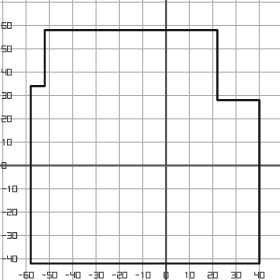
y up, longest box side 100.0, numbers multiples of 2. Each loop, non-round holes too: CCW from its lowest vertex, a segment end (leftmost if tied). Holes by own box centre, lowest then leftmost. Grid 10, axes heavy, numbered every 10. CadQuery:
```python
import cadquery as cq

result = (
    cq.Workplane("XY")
    .moveTo(-58.0, -42.0)
    .lineTo(40.0, -42.0)
    .lineTo(40.0, 28.0)
    .lineTo(22.0, 28.0)
    .lineTo(22.0, 58.0)
    .lineTo(-52.0, 58.0)
    .lineTo(-52.0, 34.0)
    .lineTo(-58.0, 34.0)
    .close()
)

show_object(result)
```